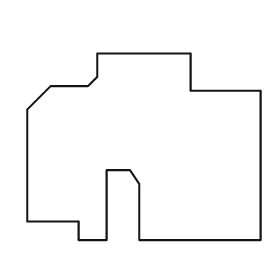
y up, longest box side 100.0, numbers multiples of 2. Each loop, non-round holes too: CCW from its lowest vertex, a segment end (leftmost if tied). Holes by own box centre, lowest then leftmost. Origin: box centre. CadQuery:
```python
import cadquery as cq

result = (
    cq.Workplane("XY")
    .moveTo(-28.0, -40.0)
    .lineTo(-16.0, -40.0)
    .lineTo(-16.0, -10.0)
    .lineTo(-6.0, -10.0)
    .lineTo(-2.0, -16.0)
    .lineTo(-2.0, -40.0)
    .lineTo(50.0, -40.0)
    .lineTo(50.0, 24.0)
    .lineTo(20.0, 24.0)
    .lineTo(20.0, 40.0)
    .lineTo(-20.0, 40.0)
    .lineTo(-20.0, 30.0)
    .lineTo(-24.0, 26.0)
    .lineTo(-40.0, 26.0)
    .lineTo(-50.0, 16.0)
    .lineTo(-50.0, -32.0)
    .lineTo(-28.0, -32.0)
    .close()
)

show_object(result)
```